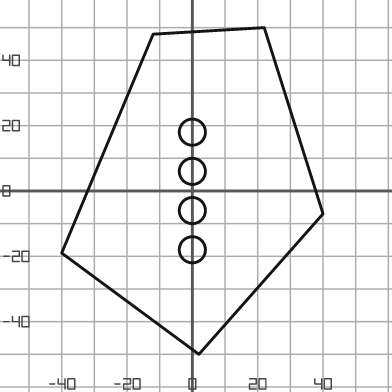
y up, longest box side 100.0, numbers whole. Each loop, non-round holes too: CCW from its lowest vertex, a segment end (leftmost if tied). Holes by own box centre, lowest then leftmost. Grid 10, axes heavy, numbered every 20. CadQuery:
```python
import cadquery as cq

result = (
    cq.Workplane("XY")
    .moveTo(2.0, -50.0)
    .lineTo(40.0, -7.0)
    .lineTo(22.0, 50.0)
    .lineTo(-12.0, 48.0)
    .lineTo(-40.0, -19.0)
    .close()
    .moveTo(0.0, -18.0)
    .circle(4.0)
    .moveTo(0.0, -6.0)
    .circle(4.0)
    .moveTo(0.0, 6.0)
    .circle(4.0)
    .moveTo(0.0, 18.0)
    .circle(4.0)
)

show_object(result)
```